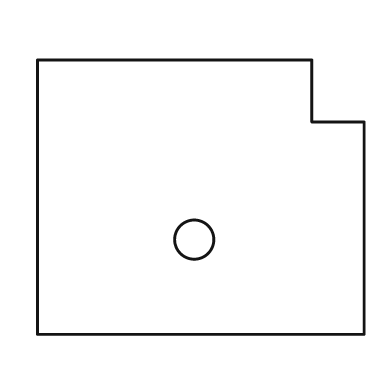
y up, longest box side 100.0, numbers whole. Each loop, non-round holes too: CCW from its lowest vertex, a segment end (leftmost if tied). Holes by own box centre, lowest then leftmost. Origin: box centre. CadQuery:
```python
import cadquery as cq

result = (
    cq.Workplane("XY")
    .moveTo(-50.0, -42.0)
    .lineTo(50.0, -42.0)
    .lineTo(50.0, 23.0)
    .lineTo(34.0, 23.0)
    .lineTo(34.0, 42.0)
    .lineTo(-50.0, 42.0)
    .close()
    .moveTo(-2.0, -13.0)
    .circle(6.0)
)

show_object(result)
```